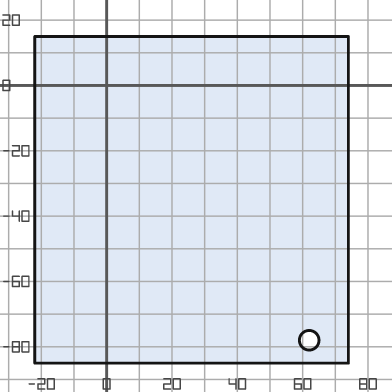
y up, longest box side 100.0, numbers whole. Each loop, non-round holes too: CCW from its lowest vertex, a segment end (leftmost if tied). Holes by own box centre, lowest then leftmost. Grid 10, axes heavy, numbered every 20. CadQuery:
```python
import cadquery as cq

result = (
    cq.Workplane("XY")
    .moveTo(-22.0, -85.0)
    .lineTo(74.0, -85.0)
    .lineTo(74.0, 15.0)
    .lineTo(-22.0, 15.0)
    .close()
    .moveTo(62.0, -78.0)
    .circle(3.0)
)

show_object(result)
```